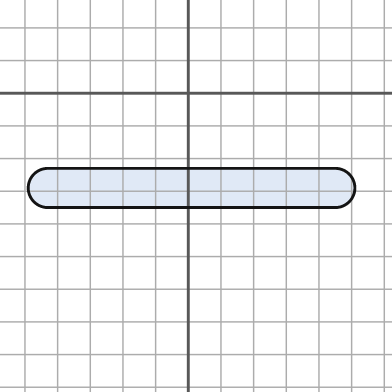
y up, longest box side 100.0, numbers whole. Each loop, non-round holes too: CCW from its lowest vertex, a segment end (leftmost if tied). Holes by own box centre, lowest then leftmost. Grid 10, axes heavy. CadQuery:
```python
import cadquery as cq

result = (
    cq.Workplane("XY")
    .moveTo(-43.0, -35.0)
    .lineTo(45.0, -35.0)
    .threePointArc((51.0, -29.0), (45.0, -23.0))
    .lineTo(-43.0, -23.0)
    .threePointArc((-49.0, -29.0), (-43.0, -35.0))
    .close()
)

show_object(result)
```